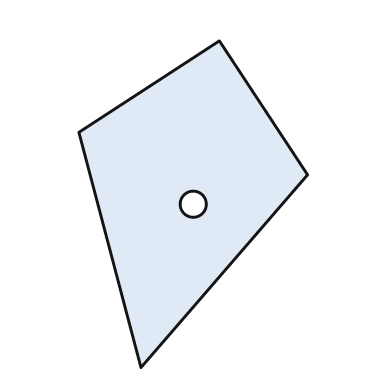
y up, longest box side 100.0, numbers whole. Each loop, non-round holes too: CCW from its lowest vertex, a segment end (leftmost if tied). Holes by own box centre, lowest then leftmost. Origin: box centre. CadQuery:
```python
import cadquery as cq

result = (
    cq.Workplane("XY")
    .moveTo(-16.0, -50.0)
    .lineTo(35.0, 9.0)
    .lineTo(8.0, 50.0)
    .lineTo(-35.0, 22.0)
    .close()
    .moveTo(0.0, 0.0)
    .circle(4.0)
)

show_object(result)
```